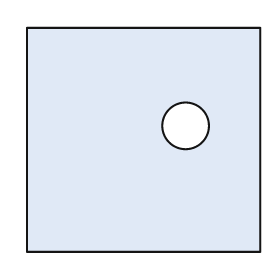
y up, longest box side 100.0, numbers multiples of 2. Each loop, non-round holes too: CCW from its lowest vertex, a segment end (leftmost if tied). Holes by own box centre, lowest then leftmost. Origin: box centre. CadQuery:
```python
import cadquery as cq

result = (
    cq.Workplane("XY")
    .moveTo(-50.0, -48.0)
    .lineTo(50.0, -48.0)
    .lineTo(50.0, 48.0)
    .lineTo(-50.0, 48.0)
    .close()
    .moveTo(18.0, 6.0)
    .circle(10.0)
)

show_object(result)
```